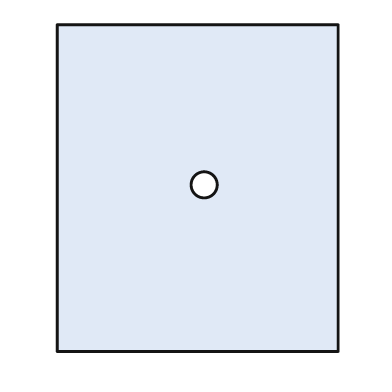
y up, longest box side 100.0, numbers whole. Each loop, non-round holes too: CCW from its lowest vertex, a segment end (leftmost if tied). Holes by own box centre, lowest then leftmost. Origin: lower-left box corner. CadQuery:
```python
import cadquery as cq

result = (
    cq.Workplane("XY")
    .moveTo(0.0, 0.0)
    .lineTo(86.0, 0.0)
    .lineTo(86.0, 100.0)
    .lineTo(0.0, 100.0)
    .close()
    .moveTo(45.0, 51.0)
    .circle(4.0)
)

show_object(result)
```